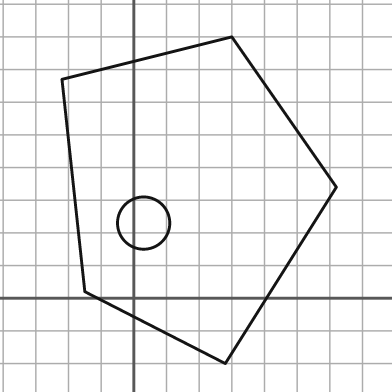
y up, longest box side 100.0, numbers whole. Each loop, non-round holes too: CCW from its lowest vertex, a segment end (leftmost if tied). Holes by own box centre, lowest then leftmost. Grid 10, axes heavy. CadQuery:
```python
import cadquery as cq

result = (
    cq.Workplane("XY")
    .moveTo(28.0, -20.0)
    .lineTo(62.0, 34.0)
    .lineTo(30.0, 80.0)
    .lineTo(-22.0, 67.0)
    .lineTo(-15.0, 2.0)
    .close()
    .moveTo(3.0, 23.0)
    .circle(8.0)
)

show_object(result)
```